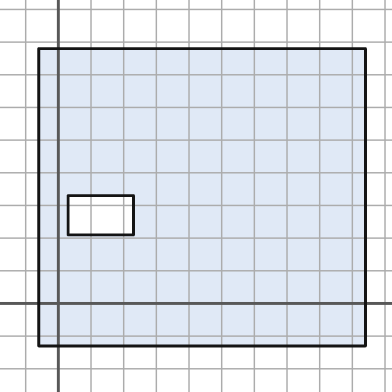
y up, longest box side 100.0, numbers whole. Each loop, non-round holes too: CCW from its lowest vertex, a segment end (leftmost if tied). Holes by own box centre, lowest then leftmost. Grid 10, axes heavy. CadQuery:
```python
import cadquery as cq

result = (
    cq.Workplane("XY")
    .moveTo(-6.0, -13.0)
    .lineTo(94.0, -13.0)
    .lineTo(94.0, 78.0)
    .lineTo(-6.0, 78.0)
    .close()
    .moveTo(3.0, 21.0)
    .lineTo(23.0, 21.0)
    .lineTo(23.0, 33.0)
    .lineTo(3.0, 33.0)
    .close()
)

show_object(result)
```